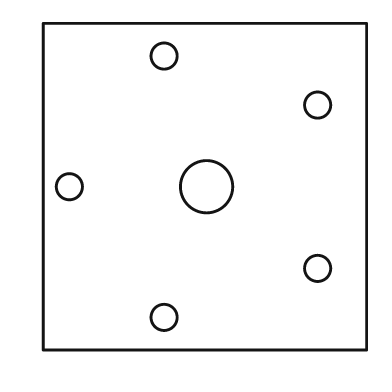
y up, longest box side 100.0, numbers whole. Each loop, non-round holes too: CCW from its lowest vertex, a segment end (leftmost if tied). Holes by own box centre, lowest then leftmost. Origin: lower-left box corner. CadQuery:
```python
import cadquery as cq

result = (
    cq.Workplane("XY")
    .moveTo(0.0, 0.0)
    .lineTo(99.0, 0.0)
    .lineTo(99.0, 100.0)
    .lineTo(0.0, 100.0)
    .close()
    .moveTo(37.0, 10.0)
    .circle(4.0)
    .moveTo(84.0, 25.0)
    .circle(4.0)
    .moveTo(8.0, 50.0)
    .circle(4.0)
    .moveTo(50.0, 50.0)
    .circle(8.0)
    .moveTo(84.0, 75.0)
    .circle(4.0)
    .moveTo(37.0, 90.0)
    .circle(4.0)
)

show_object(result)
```